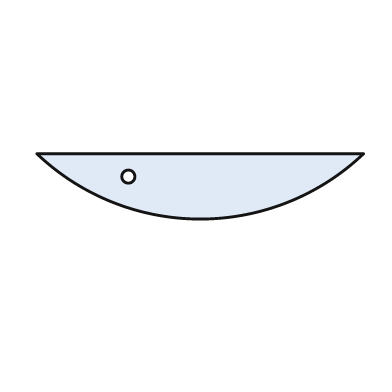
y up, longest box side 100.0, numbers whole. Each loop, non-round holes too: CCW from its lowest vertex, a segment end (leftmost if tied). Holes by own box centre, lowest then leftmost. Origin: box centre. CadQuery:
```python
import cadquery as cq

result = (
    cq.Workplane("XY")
    .moveTo(-50.0, 10.0)
    .threePointArc((0.0, -10.0), (50.0, 10.0))
    .close()
    .moveTo(-22.0, 3.0)
    .circle(2.0)
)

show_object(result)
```